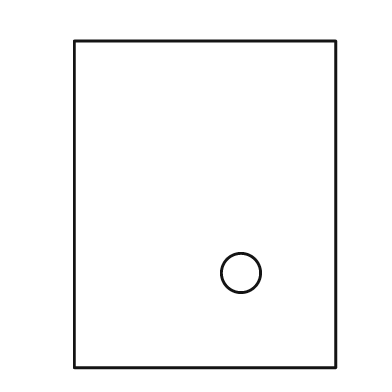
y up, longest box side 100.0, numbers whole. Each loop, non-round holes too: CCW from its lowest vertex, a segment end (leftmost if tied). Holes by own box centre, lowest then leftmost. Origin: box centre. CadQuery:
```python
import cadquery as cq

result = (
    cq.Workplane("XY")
    .moveTo(-40.0, -50.0)
    .lineTo(40.0, -50.0)
    .lineTo(40.0, 50.0)
    .lineTo(-40.0, 50.0)
    .close()
    .moveTo(11.0, -21.0)
    .circle(6.0)
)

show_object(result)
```